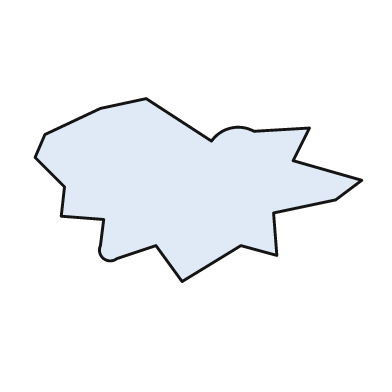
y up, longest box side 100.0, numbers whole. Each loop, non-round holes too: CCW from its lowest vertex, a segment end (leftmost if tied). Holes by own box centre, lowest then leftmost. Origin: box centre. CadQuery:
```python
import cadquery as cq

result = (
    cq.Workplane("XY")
    .moveTo(-5.0, -28.0)
    .lineTo(13.0, -17.0)
    .lineTo(24.0, -20.0)
    .lineTo(23.0, -7.0)
    .lineTo(42.0, -3.0)
    .lineTo(50.0, 3.0)
    .lineTo(29.0, 9.0)
    .lineTo(34.0, 19.0)
    .lineTo(17.0, 18.0)
    .threePointArc((10.0, 19.0), (4.0, 15.0))
    .lineTo(-16.0, 28.0)
    .lineTo(-30.0, 25.0)
    .lineTo(-47.0, 17.0)
    .lineTo(-50.0, 10.0)
    .lineTo(-41.0, 1.0)
    .lineTo(-42.0, -8.0)
    .lineTo(-29.0, -9.0)
    .lineTo(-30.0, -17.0)
    .threePointArc((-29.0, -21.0), (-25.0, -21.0))
    .lineTo(-13.0, -17.0)
    .close()
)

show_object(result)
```